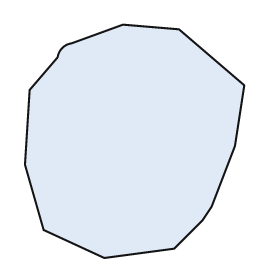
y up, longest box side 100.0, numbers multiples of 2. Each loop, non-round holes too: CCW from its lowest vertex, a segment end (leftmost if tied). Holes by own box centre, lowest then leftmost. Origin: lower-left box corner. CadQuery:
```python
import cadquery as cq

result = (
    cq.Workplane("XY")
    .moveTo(34.0, 0.0)
    .lineTo(64.0, 4.0)
    .lineTo(76.0, 16.0)
    .lineTo(80.0, 22.0)
    .lineTo(90.0, 48.0)
    .lineTo(94.0, 74.0)
    .lineTo(66.0, 98.0)
    .lineTo(42.0, 100.0)
    .lineTo(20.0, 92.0)
    .threePointArc((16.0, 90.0), (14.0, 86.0))
    .lineTo(2.0, 72.0)
    .lineTo(0.0, 40.0)
    .lineTo(8.0, 12.0)
    .close()
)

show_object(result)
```